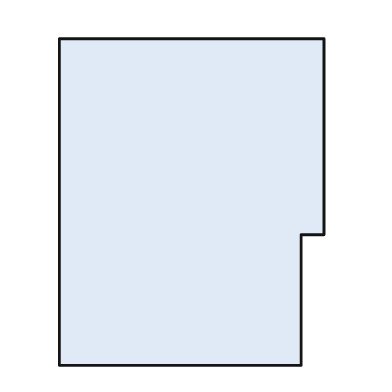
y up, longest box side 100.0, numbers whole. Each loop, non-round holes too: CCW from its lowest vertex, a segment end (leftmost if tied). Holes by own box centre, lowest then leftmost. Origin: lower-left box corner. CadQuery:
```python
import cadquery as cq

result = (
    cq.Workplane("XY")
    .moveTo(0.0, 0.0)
    .lineTo(74.0, 0.0)
    .lineTo(74.0, 40.0)
    .lineTo(81.0, 40.0)
    .lineTo(81.0, 100.0)
    .lineTo(0.0, 100.0)
    .close()
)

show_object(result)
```